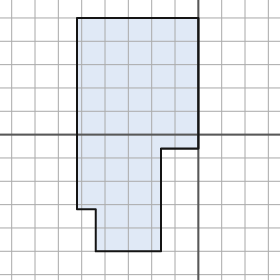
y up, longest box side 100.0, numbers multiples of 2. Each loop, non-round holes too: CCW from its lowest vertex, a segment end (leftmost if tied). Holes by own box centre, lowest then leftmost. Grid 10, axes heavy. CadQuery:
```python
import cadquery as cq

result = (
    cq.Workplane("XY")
    .moveTo(-44.0, -50.0)
    .lineTo(-16.0, -50.0)
    .lineTo(-16.0, -6.0)
    .lineTo(0.0, -6.0)
    .lineTo(0.0, 50.0)
    .lineTo(-52.0, 50.0)
    .lineTo(-52.0, -32.0)
    .lineTo(-44.0, -32.0)
    .close()
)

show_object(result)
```